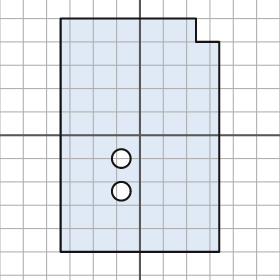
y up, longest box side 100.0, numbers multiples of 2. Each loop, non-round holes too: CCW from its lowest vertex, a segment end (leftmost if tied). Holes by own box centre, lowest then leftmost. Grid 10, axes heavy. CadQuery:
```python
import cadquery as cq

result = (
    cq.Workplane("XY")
    .moveTo(-34.0, -50.0)
    .lineTo(34.0, -50.0)
    .lineTo(34.0, 40.0)
    .lineTo(24.0, 40.0)
    .lineTo(24.0, 50.0)
    .lineTo(-34.0, 50.0)
    .close()
    .moveTo(-8.0, -24.0)
    .circle(4.0)
    .moveTo(-8.0, -10.0)
    .circle(4.0)
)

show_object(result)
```